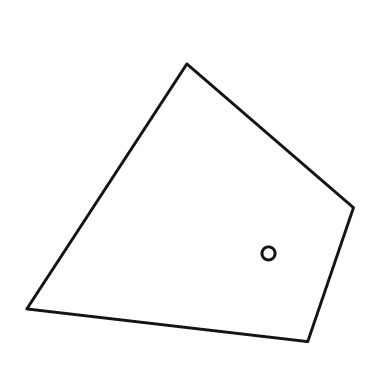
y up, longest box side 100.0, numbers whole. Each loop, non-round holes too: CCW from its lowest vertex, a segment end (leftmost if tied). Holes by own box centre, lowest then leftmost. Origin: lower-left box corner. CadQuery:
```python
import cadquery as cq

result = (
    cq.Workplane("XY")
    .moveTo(86.0, 0.0)
    .lineTo(100.0, 41.0)
    .lineTo(49.0, 85.0)
    .lineTo(0.0, 10.0)
    .close()
    .moveTo(74.0, 27.0)
    .circle(2.0)
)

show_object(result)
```